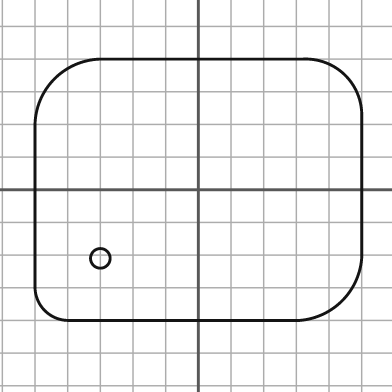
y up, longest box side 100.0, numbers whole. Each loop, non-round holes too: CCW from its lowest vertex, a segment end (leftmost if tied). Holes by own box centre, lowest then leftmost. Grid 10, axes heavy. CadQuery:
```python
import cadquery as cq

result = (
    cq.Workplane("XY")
    .moveTo(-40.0, -40.0)
    .lineTo(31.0, -40.0)
    .threePointArc((44.0, -34.0), (50.0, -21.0))
    .lineTo(50.0, 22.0)
    .threePointArc((45.0, 35.0), (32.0, 40.0))
    .lineTo(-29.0, 40.0)
    .threePointArc((-44.0, 34.0), (-50.0, 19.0))
    .lineTo(-50.0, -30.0)
    .threePointArc((-47.0, -37.0), (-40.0, -40.0))
    .close()
    .moveTo(-30.0, -21.0)
    .circle(3.0)
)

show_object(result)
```